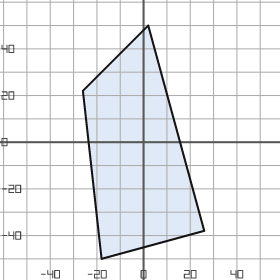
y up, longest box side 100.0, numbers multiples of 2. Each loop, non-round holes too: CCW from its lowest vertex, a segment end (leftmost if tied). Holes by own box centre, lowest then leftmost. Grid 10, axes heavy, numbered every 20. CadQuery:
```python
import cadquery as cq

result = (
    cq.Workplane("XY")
    .moveTo(-18.0, -50.0)
    .lineTo(26.0, -38.0)
    .lineTo(2.0, 50.0)
    .lineTo(-26.0, 22.0)
    .close()
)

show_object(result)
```